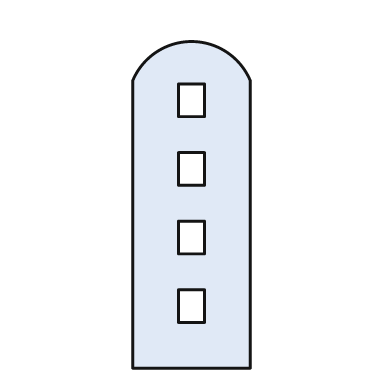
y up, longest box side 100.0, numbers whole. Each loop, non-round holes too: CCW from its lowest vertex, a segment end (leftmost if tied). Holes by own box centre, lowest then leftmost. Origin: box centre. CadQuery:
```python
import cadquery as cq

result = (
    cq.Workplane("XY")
    .moveTo(-18.0, -50.0)
    .lineTo(18.0, -50.0)
    .lineTo(18.0, 38.0)
    .threePointArc((0.0, 50.0), (-18.0, 38.0))
    .close()
    .moveTo(-4.0, -36.0)
    .lineTo(4.0, -36.0)
    .lineTo(4.0, -26.0)
    .lineTo(-4.0, -26.0)
    .close()
    .moveTo(-4.0, -15.0)
    .lineTo(4.0, -15.0)
    .lineTo(4.0, -5.0)
    .lineTo(-4.0, -5.0)
    .close()
    .moveTo(-4.0, 6.0)
    .lineTo(4.0, 6.0)
    .lineTo(4.0, 16.0)
    .lineTo(-4.0, 16.0)
    .close()
    .moveTo(-4.0, 27.0)
    .lineTo(4.0, 27.0)
    .lineTo(4.0, 37.0)
    .lineTo(-4.0, 37.0)
    .close()
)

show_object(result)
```